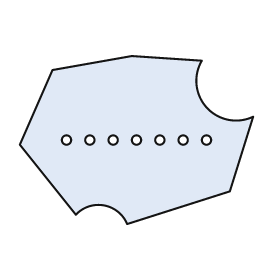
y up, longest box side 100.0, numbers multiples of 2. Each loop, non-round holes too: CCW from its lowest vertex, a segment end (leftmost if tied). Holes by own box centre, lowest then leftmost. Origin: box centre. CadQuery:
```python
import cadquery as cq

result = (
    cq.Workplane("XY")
    .moveTo(-4.0, -36.0)
    .lineTo(40.0, -22.0)
    .lineTo(50.0, 10.0)
    .threePointArc((30.0, 14.0), (28.0, 34.0))
    .lineTo(-2.0, 36.0)
    .lineTo(-36.0, 30.0)
    .lineTo(-50.0, -2.0)
    .lineTo(-26.0, -32.0)
    .threePointArc((-14.0, -28.0), (-4.0, -36.0))
    .close()
    .moveTo(-30.0, 0.0)
    .circle(2.0)
    .moveTo(-20.0, 0.0)
    .circle(2.0)
    .moveTo(-10.0, 0.0)
    .circle(2.0)
    .moveTo(0.0, 0.0)
    .circle(2.0)
    .moveTo(10.0, 0.0)
    .circle(2.0)
    .moveTo(20.0, 0.0)
    .circle(2.0)
    .moveTo(30.0, 0.0)
    .circle(2.0)
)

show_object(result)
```